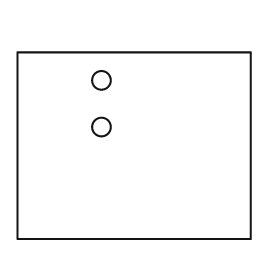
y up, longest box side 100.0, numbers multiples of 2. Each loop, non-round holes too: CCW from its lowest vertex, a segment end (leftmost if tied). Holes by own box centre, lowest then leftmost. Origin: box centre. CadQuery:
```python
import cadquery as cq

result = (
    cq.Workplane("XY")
    .moveTo(-50.0, -40.0)
    .lineTo(50.0, -40.0)
    .lineTo(50.0, 40.0)
    .lineTo(-50.0, 40.0)
    .close()
    .moveTo(-14.0, 8.0)
    .circle(4.0)
    .moveTo(-14.0, 28.0)
    .circle(4.0)
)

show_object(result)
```